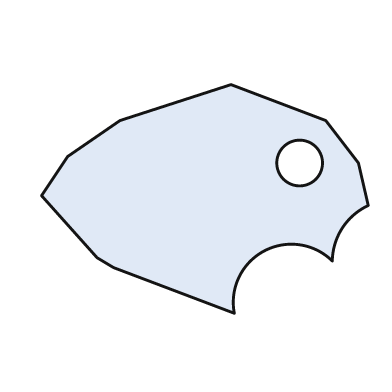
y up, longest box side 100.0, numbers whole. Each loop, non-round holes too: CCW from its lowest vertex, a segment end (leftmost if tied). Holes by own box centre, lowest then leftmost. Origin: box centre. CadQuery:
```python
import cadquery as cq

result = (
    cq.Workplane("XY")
    .moveTo(9.0, -35.0)
    .threePointArc((18.0, -16.0), (39.0, -19.0))
    .threePointArc((42.0, -9.0), (50.0, -2.0))
    .lineTo(47.0, 11.0)
    .lineTo(37.0, 24.0)
    .lineTo(8.0, 35.0)
    .lineTo(-26.0, 24.0)
    .lineTo(-42.0, 13.0)
    .lineTo(-50.0, 1.0)
    .lineTo(-33.0, -18.0)
    .lineTo(-28.0, -21.0)
    .close()
    .moveTo(29.0, 11.0)
    .circle(7.0)
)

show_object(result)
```